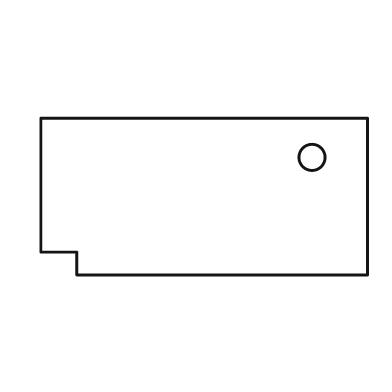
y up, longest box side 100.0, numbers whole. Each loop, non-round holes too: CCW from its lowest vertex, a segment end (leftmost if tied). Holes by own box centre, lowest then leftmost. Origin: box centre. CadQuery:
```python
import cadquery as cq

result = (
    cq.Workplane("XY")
    .moveTo(-39.0, -24.0)
    .lineTo(50.0, -24.0)
    .lineTo(50.0, 24.0)
    .lineTo(-50.0, 24.0)
    .lineTo(-50.0, -17.0)
    .lineTo(-39.0, -17.0)
    .close()
    .moveTo(33.0, 12.0)
    .circle(4.0)
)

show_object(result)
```